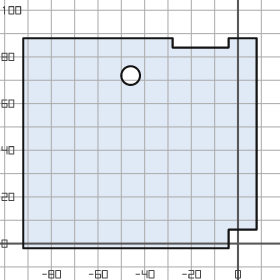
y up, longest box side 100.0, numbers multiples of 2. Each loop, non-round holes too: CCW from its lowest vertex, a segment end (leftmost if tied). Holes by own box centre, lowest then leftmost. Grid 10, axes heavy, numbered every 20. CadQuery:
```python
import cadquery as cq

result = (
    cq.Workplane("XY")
    .moveTo(-92.0, -2.0)
    .lineTo(-4.0, -2.0)
    .lineTo(-4.0, 6.0)
    .lineTo(8.0, 6.0)
    .lineTo(8.0, 88.0)
    .lineTo(-4.0, 88.0)
    .lineTo(-4.0, 84.0)
    .lineTo(-28.0, 84.0)
    .lineTo(-28.0, 88.0)
    .lineTo(-92.0, 88.0)
    .close()
    .moveTo(-46.0, 72.0)
    .circle(4.0)
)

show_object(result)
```